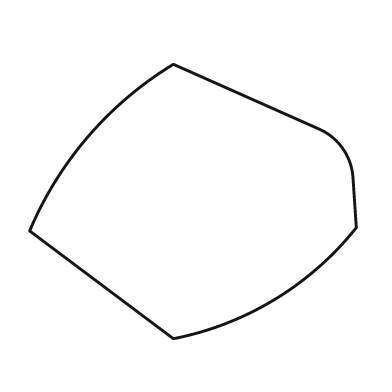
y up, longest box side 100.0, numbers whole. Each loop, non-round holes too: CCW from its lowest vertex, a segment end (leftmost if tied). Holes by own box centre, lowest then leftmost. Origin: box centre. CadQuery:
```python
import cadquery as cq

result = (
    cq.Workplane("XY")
    .moveTo(-6.0, -42.0)
    .threePointArc((25.0, -30.0), (50.0, -8.0))
    .lineTo(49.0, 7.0)
    .threePointArc((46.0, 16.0), (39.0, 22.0))
    .lineTo(-6.0, 42.0)
    .threePointArc((-32.0, 20.0), (-50.0, -9.0))
    .close()
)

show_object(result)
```